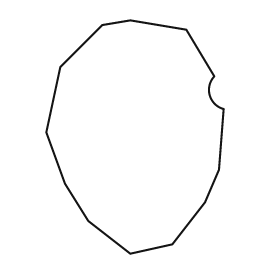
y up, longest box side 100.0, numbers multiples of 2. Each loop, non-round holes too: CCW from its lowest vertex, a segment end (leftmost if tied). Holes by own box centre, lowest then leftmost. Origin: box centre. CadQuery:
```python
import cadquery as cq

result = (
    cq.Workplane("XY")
    .moveTo(-2.0, -50.0)
    .lineTo(16.0, -46.0)
    .lineTo(30.0, -28.0)
    .lineTo(36.0, -14.0)
    .lineTo(38.0, 12.0)
    .threePointArc((32.0, 18.0), (34.0, 26.0))
    .lineTo(22.0, 46.0)
    .lineTo(-2.0, 50.0)
    .lineTo(-14.0, 48.0)
    .lineTo(-32.0, 30.0)
    .lineTo(-38.0, 2.0)
    .lineTo(-30.0, -20.0)
    .lineTo(-20.0, -36.0)
    .close()
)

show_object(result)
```